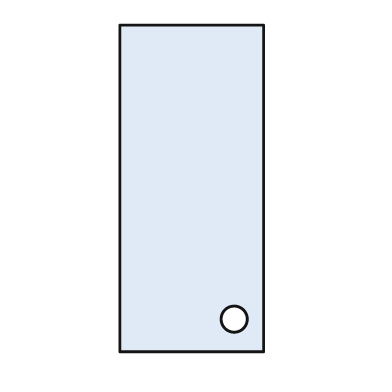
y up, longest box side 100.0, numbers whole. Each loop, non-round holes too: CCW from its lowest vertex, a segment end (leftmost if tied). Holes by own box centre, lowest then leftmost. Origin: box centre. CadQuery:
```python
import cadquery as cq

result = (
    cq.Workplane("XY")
    .moveTo(-22.0, -50.0)
    .lineTo(22.0, -50.0)
    .lineTo(22.0, 50.0)
    .lineTo(-22.0, 50.0)
    .close()
    .moveTo(13.0, -40.0)
    .circle(4.0)
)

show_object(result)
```